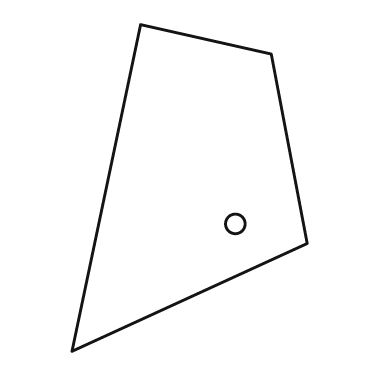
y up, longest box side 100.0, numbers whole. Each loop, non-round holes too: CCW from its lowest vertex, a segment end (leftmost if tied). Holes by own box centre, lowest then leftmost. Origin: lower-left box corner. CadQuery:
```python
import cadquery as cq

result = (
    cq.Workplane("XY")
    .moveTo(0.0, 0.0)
    .lineTo(72.0, 33.0)
    .lineTo(61.0, 91.0)
    .lineTo(21.0, 100.0)
    .close()
    .moveTo(50.0, 39.0)
    .circle(3.0)
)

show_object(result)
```